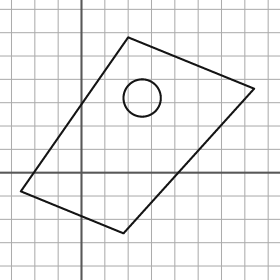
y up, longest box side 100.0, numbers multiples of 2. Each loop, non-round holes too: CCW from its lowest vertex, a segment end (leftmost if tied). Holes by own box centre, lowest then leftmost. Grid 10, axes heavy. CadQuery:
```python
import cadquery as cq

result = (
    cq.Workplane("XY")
    .moveTo(18.0, -26.0)
    .lineTo(74.0, 36.0)
    .lineTo(20.0, 58.0)
    .lineTo(-26.0, -8.0)
    .close()
    .moveTo(26.0, 32.0)
    .circle(8.0)
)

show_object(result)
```